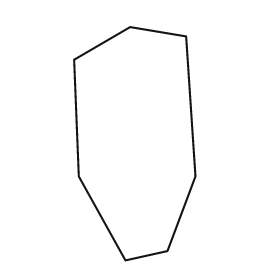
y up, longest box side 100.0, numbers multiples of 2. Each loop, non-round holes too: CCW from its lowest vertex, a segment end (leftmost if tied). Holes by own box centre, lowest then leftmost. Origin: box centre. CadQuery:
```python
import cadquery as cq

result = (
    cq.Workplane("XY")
    .moveTo(-4.0, -50.0)
    .lineTo(14.0, -46.0)
    .lineTo(26.0, -14.0)
    .lineTo(22.0, 46.0)
    .lineTo(-2.0, 50.0)
    .lineTo(-26.0, 36.0)
    .lineTo(-24.0, -14.0)
    .close()
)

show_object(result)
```